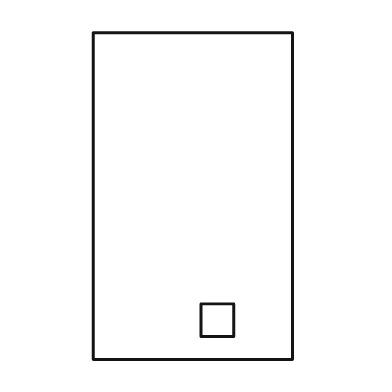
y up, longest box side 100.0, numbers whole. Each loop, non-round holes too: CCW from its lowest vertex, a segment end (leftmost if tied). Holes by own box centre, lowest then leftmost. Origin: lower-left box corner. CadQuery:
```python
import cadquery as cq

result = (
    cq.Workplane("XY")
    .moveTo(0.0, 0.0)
    .lineTo(61.0, 0.0)
    .lineTo(61.0, 100.0)
    .lineTo(0.0, 100.0)
    .close()
    .moveTo(33.0, 7.0)
    .lineTo(43.0, 7.0)
    .lineTo(43.0, 17.0)
    .lineTo(33.0, 17.0)
    .close()
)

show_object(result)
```